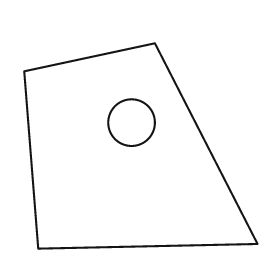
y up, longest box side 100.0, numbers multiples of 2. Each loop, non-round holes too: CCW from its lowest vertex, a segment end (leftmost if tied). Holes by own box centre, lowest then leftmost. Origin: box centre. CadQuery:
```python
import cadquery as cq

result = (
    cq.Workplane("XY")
    .moveTo(-44.0, -44.0)
    .lineTo(50.0, -42.0)
    .lineTo(6.0, 44.0)
    .lineTo(-50.0, 32.0)
    .close()
    .moveTo(-4.0, 10.0)
    .circle(10.0)
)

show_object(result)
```